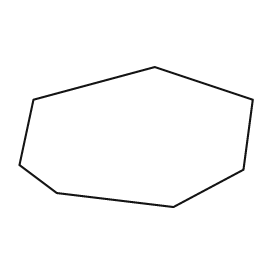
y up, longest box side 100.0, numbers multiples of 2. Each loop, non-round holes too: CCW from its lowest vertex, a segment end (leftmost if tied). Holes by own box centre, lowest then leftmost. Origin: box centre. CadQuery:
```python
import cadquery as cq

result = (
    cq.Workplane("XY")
    .moveTo(16.0, -30.0)
    .lineTo(46.0, -14.0)
    .lineTo(50.0, 16.0)
    .lineTo(8.0, 30.0)
    .lineTo(-44.0, 16.0)
    .lineTo(-50.0, -12.0)
    .lineTo(-34.0, -24.0)
    .close()
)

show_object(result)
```